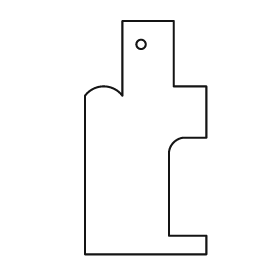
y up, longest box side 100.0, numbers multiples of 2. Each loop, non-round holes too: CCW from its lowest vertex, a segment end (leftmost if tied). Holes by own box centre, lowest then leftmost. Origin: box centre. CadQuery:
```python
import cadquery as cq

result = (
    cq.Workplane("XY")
    .moveTo(-26.0, -50.0)
    .lineTo(26.0, -50.0)
    .lineTo(26.0, -42.0)
    .lineTo(10.0, -42.0)
    .lineTo(10.0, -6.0)
    .threePointArc((12.0, -2.0), (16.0, 0.0))
    .lineTo(26.0, 0.0)
    .lineTo(26.0, 22.0)
    .lineTo(12.0, 22.0)
    .lineTo(12.0, 50.0)
    .lineTo(-10.0, 50.0)
    .lineTo(-10.0, 18.0)
    .threePointArc((-18.0, 22.0), (-26.0, 18.0))
    .close()
    .moveTo(-2.0, 40.0)
    .circle(2.0)
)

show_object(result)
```